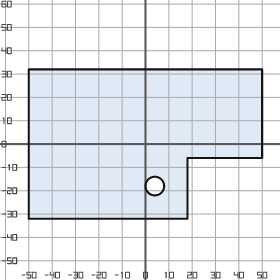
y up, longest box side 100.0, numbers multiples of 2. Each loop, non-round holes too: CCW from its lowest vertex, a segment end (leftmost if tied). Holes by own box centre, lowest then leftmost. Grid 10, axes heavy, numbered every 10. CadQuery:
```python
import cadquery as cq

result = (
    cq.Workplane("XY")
    .moveTo(-50.0, -32.0)
    .lineTo(18.0, -32.0)
    .lineTo(18.0, -6.0)
    .lineTo(50.0, -6.0)
    .lineTo(50.0, 32.0)
    .lineTo(-50.0, 32.0)
    .close()
    .moveTo(4.0, -18.0)
    .circle(4.0)
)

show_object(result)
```